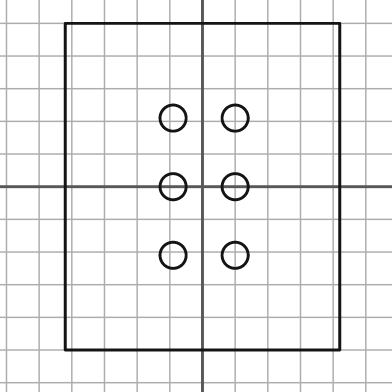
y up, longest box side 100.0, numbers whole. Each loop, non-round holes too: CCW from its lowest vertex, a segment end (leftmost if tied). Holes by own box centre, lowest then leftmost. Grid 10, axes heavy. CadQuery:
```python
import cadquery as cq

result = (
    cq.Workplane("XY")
    .moveTo(-42.0, -50.0)
    .lineTo(42.0, -50.0)
    .lineTo(42.0, 50.0)
    .lineTo(-42.0, 50.0)
    .close()
    .moveTo(-9.0, -21.0)
    .circle(4.0)
    .moveTo(10.0, -21.0)
    .circle(4.0)
    .moveTo(-9.0, 0.0)
    .circle(4.0)
    .moveTo(10.0, 0.0)
    .circle(4.0)
    .moveTo(-9.0, 21.0)
    .circle(4.0)
    .moveTo(10.0, 21.0)
    .circle(4.0)
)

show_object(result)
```